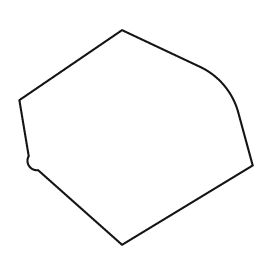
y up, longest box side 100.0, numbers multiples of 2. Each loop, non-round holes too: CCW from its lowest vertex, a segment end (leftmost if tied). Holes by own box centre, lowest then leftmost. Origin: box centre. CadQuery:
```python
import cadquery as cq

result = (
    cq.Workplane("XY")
    .moveTo(-6.0, -46.0)
    .lineTo(50.0, -12.0)
    .lineTo(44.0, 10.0)
    .threePointArc((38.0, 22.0), (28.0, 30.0))
    .lineTo(-6.0, 46.0)
    .lineTo(-50.0, 16.0)
    .lineTo(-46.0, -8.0)
    .threePointArc((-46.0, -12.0), (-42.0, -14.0))
    .close()
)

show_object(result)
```